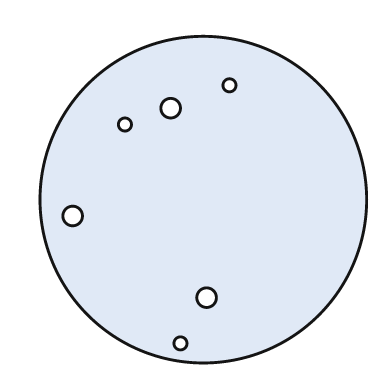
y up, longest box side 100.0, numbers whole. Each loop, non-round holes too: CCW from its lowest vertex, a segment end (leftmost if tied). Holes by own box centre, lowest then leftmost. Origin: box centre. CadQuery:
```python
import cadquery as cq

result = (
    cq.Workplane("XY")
    .moveTo(0.0, 0.0)
    .circle(50.0)
    .moveTo(-7.0, -44.0)
    .circle(2.0)
    .moveTo(1.0, -30.0)
    .circle(3.0)
    .moveTo(-40.0, -5.0)
    .circle(3.0)
    .moveTo(-24.0, 23.0)
    .circle(2.0)
    .moveTo(-10.0, 28.0)
    .circle(3.0)
    .moveTo(8.0, 35.0)
    .circle(2.0)
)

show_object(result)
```